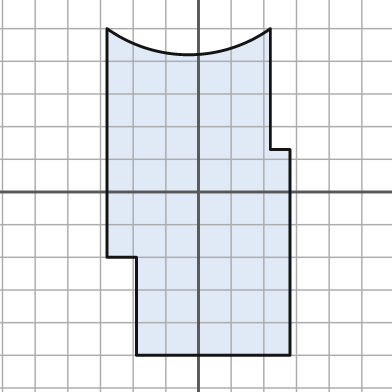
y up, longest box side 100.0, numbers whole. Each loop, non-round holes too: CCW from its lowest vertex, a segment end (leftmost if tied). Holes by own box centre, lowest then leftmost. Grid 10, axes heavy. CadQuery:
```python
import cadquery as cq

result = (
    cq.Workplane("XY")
    .moveTo(-19.0, -50.0)
    .lineTo(28.0, -50.0)
    .lineTo(28.0, 13.0)
    .lineTo(22.0, 13.0)
    .lineTo(22.0, 50.0)
    .threePointArc((-3.0, 42.0), (-28.0, 50.0))
    .lineTo(-28.0, -20.0)
    .lineTo(-19.0, -20.0)
    .close()
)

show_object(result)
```